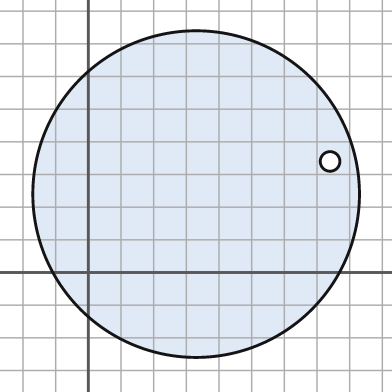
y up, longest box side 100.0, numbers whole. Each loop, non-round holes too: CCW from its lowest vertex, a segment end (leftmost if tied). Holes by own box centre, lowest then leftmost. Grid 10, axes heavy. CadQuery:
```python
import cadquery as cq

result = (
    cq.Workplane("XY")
    .moveTo(33.0, 24.0)
    .circle(50.0)
    .moveTo(74.0, 34.0)
    .circle(3.0)
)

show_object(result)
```